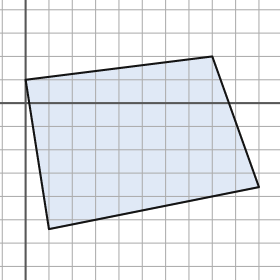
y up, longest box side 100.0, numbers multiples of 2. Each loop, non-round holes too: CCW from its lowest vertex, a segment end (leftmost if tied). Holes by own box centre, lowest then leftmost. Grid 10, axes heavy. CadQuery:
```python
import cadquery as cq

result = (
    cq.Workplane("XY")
    .moveTo(10.0, -54.0)
    .lineTo(100.0, -36.0)
    .lineTo(80.0, 20.0)
    .lineTo(0.0, 10.0)
    .close()
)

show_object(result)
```